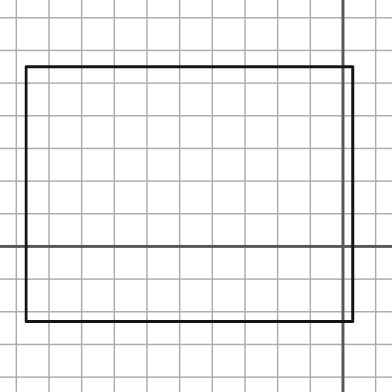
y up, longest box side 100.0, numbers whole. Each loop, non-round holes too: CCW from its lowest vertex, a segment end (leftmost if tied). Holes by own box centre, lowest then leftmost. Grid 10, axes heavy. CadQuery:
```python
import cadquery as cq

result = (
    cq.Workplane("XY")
    .moveTo(-97.0, -23.0)
    .lineTo(3.0, -23.0)
    .lineTo(3.0, 55.0)
    .lineTo(-97.0, 55.0)
    .close()
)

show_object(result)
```